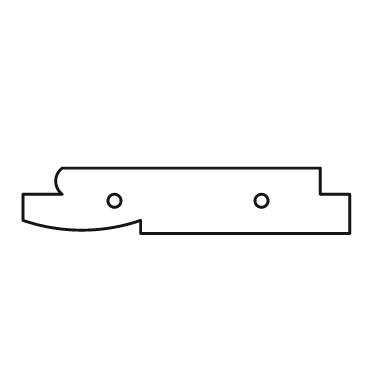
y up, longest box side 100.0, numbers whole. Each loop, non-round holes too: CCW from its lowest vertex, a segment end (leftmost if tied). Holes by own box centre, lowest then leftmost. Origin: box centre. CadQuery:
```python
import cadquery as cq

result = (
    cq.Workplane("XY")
    .moveTo(-14.0, -10.0)
    .lineTo(50.0, -10.0)
    .lineTo(50.0, 2.0)
    .lineTo(41.0, 2.0)
    .lineTo(41.0, 10.0)
    .lineTo(-38.0, 10.0)
    .threePointArc((-40.0, 6.0), (-38.0, 2.0))
    .lineTo(-50.0, 2.0)
    .lineTo(-50.0, -6.0)
    .threePointArc((-32.0, -9.0), (-14.0, -6.0))
    .close()
    .moveTo(-22.0, 0.0)
    .circle(2.0)
    .moveTo(23.0, 0.0)
    .circle(2.0)
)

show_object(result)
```